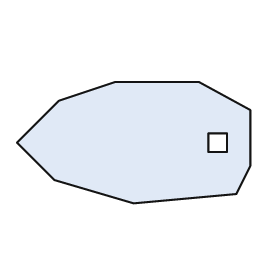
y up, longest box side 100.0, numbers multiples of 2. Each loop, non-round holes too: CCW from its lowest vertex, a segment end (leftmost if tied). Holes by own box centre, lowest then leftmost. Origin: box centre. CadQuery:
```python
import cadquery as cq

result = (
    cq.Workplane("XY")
    .moveTo(0.0, -26.0)
    .lineTo(44.0, -22.0)
    .lineTo(50.0, -10.0)
    .lineTo(50.0, 14.0)
    .lineTo(28.0, 26.0)
    .lineTo(-8.0, 26.0)
    .lineTo(-32.0, 18.0)
    .lineTo(-50.0, 0.0)
    .lineTo(-34.0, -16.0)
    .close()
    .moveTo(32.0, -4.0)
    .lineTo(40.0, -4.0)
    .lineTo(40.0, 4.0)
    .lineTo(32.0, 4.0)
    .close()
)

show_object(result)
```